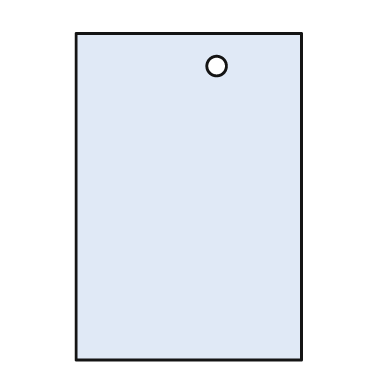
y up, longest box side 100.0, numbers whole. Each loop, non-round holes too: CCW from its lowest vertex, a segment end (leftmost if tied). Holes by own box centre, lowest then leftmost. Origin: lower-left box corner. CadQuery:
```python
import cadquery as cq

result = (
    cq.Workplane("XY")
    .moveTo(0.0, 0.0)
    .lineTo(69.0, 0.0)
    .lineTo(69.0, 100.0)
    .lineTo(0.0, 100.0)
    .close()
    .moveTo(43.0, 90.0)
    .circle(3.0)
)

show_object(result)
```